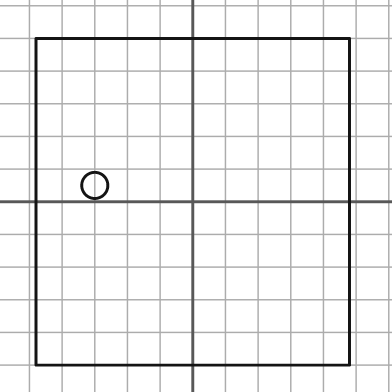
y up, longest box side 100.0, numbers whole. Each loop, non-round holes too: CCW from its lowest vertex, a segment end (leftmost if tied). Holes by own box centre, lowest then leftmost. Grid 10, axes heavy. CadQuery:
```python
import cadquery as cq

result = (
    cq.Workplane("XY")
    .moveTo(-48.0, -50.0)
    .lineTo(48.0, -50.0)
    .lineTo(48.0, 50.0)
    .lineTo(-48.0, 50.0)
    .close()
    .moveTo(-30.0, 5.0)
    .circle(4.0)
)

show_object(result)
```